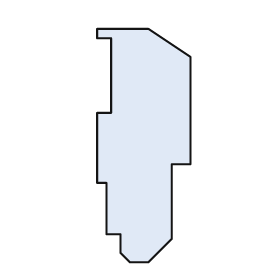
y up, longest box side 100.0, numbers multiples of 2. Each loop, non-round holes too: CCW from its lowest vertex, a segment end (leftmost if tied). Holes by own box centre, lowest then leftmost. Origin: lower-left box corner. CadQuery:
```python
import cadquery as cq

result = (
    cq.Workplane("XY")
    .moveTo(14.0, 0.0)
    .lineTo(22.0, 0.0)
    .lineTo(32.0, 10.0)
    .lineTo(32.0, 42.0)
    .lineTo(40.0, 42.0)
    .lineTo(40.0, 88.0)
    .lineTo(22.0, 100.0)
    .lineTo(0.0, 100.0)
    .lineTo(0.0, 96.0)
    .lineTo(6.0, 96.0)
    .lineTo(6.0, 64.0)
    .lineTo(0.0, 64.0)
    .lineTo(0.0, 34.0)
    .lineTo(4.0, 34.0)
    .lineTo(4.0, 12.0)
    .lineTo(10.0, 12.0)
    .lineTo(10.0, 4.0)
    .close()
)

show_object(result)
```